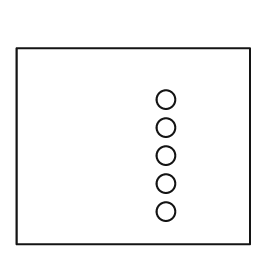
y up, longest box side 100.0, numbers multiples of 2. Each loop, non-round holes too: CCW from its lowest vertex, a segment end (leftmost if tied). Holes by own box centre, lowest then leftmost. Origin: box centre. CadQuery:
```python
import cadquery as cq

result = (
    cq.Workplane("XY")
    .moveTo(-50.0, -42.0)
    .lineTo(50.0, -42.0)
    .lineTo(50.0, 42.0)
    .lineTo(-50.0, 42.0)
    .close()
    .moveTo(14.0, -28.0)
    .circle(4.0)
    .moveTo(14.0, -16.0)
    .circle(4.0)
    .moveTo(14.0, -4.0)
    .circle(4.0)
    .moveTo(14.0, 8.0)
    .circle(4.0)
    .moveTo(14.0, 20.0)
    .circle(4.0)
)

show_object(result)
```